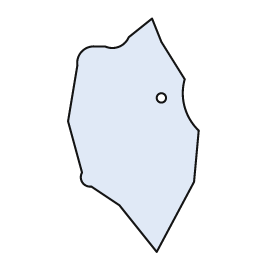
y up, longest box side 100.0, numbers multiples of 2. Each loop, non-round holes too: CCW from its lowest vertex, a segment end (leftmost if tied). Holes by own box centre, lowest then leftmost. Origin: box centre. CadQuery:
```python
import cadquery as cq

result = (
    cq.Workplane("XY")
    .moveTo(10.0, -50.0)
    .lineTo(26.0, -20.0)
    .lineTo(28.0, 2.0)
    .threePointArc((22.0, 12.0), (22.0, 24.0))
    .lineTo(12.0, 40.0)
    .lineTo(8.0, 50.0)
    .lineTo(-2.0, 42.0)
    .threePointArc((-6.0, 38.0), (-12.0, 38.0))
    .lineTo(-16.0, 38.0)
    .threePointArc((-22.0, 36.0), (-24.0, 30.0))
    .lineTo(-28.0, 6.0)
    .lineTo(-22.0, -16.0)
    .threePointArc((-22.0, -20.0), (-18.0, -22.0))
    .lineTo(-6.0, -30.0)
    .close()
    .moveTo(12.0, 16.0)
    .circle(2.0)
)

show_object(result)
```